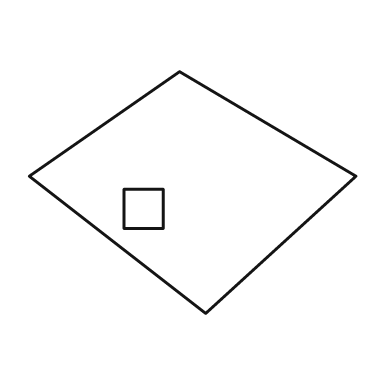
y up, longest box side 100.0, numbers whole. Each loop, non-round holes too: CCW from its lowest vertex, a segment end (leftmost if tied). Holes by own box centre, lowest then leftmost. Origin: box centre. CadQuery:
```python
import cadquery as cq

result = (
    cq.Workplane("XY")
    .moveTo(4.0, -37.0)
    .lineTo(50.0, 5.0)
    .lineTo(-4.0, 37.0)
    .lineTo(-50.0, 5.0)
    .close()
    .moveTo(-21.0, -11.0)
    .lineTo(-9.0, -11.0)
    .lineTo(-9.0, 1.0)
    .lineTo(-21.0, 1.0)
    .close()
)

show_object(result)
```